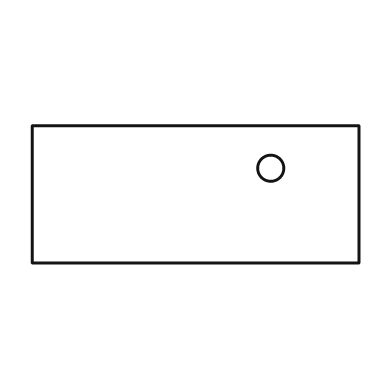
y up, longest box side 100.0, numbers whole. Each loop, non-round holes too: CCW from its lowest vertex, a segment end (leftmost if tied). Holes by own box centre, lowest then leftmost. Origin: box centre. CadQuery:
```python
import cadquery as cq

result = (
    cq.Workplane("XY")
    .moveTo(-50.0, -21.0)
    .lineTo(50.0, -21.0)
    .lineTo(50.0, 21.0)
    .lineTo(-50.0, 21.0)
    .close()
    .moveTo(23.0, 8.0)
    .circle(4.0)
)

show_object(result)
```